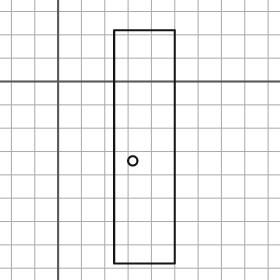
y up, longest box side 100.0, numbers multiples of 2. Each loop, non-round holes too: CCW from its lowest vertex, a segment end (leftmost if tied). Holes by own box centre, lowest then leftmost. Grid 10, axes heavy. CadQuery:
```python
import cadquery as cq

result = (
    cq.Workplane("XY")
    .moveTo(24.0, -78.0)
    .lineTo(50.0, -78.0)
    .lineTo(50.0, 22.0)
    .lineTo(24.0, 22.0)
    .close()
    .moveTo(32.0, -34.0)
    .circle(2.0)
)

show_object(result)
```